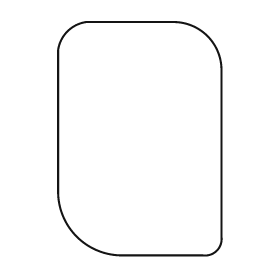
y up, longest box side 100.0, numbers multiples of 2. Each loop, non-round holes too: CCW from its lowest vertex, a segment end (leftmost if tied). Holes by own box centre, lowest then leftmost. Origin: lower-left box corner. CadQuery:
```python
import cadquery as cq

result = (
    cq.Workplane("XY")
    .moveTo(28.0, 0.0)
    .lineTo(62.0, 0.0)
    .threePointArc((68.0, 2.0), (70.0, 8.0))
    .lineTo(70.0, 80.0)
    .threePointArc((64.0, 94.0), (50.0, 100.0))
    .lineTo(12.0, 100.0)
    .threePointArc((4.0, 96.0), (0.0, 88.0))
    .lineTo(0.0, 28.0)
    .threePointArc((8.0, 8.0), (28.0, 0.0))
    .close()
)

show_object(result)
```